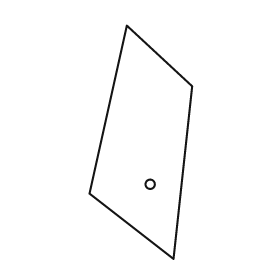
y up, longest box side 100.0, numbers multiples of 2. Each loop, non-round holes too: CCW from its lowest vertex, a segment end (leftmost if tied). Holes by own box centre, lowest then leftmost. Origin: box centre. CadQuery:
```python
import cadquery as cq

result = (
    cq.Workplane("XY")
    .moveTo(14.0, -50.0)
    .lineTo(22.0, 24.0)
    .lineTo(-6.0, 50.0)
    .lineTo(-22.0, -22.0)
    .close()
    .moveTo(4.0, -18.0)
    .circle(2.0)
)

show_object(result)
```